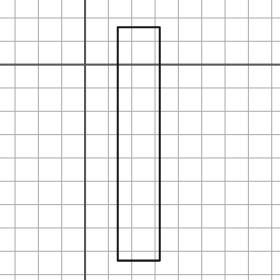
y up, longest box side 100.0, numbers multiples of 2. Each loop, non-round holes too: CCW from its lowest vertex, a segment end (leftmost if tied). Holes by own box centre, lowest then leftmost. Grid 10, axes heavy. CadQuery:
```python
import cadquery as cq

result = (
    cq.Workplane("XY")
    .moveTo(14.0, -84.0)
    .lineTo(32.0, -84.0)
    .lineTo(32.0, 16.0)
    .lineTo(14.0, 16.0)
    .close()
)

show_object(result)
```